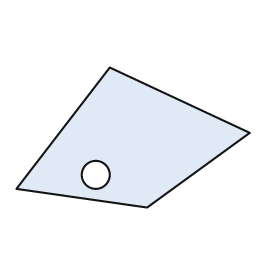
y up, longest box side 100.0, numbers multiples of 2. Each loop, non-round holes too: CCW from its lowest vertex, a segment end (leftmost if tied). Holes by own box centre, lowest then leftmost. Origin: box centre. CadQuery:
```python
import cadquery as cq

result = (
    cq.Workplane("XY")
    .moveTo(6.0, -30.0)
    .lineTo(50.0, 2.0)
    .lineTo(-10.0, 30.0)
    .lineTo(-50.0, -22.0)
    .close()
    .moveTo(-16.0, -16.0)
    .circle(6.0)
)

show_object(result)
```